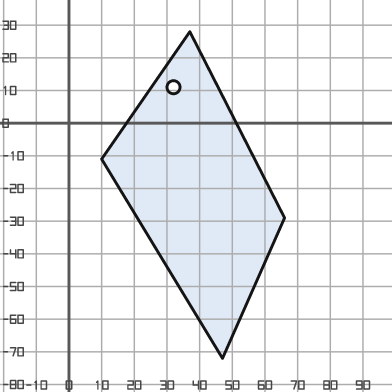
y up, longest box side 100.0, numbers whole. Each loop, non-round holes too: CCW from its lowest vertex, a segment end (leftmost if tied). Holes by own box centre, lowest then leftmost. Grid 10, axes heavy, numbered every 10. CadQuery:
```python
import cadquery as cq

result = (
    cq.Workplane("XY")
    .moveTo(47.0, -72.0)
    .lineTo(66.0, -29.0)
    .lineTo(37.0, 28.0)
    .lineTo(10.0, -11.0)
    .close()
    .moveTo(32.0, 11.0)
    .circle(2.0)
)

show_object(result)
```